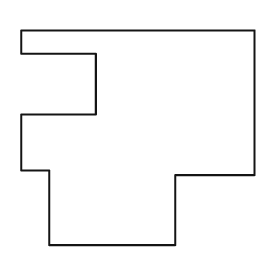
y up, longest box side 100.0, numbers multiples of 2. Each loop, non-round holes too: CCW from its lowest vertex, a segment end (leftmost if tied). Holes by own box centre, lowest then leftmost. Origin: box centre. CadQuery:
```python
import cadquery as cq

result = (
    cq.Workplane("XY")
    .moveTo(-38.0, -46.0)
    .lineTo(16.0, -46.0)
    .lineTo(16.0, -16.0)
    .lineTo(50.0, -16.0)
    .lineTo(50.0, 46.0)
    .lineTo(-50.0, 46.0)
    .lineTo(-50.0, 36.0)
    .lineTo(-18.0, 36.0)
    .lineTo(-18.0, 10.0)
    .lineTo(-50.0, 10.0)
    .lineTo(-50.0, -14.0)
    .lineTo(-38.0, -14.0)
    .close()
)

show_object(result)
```